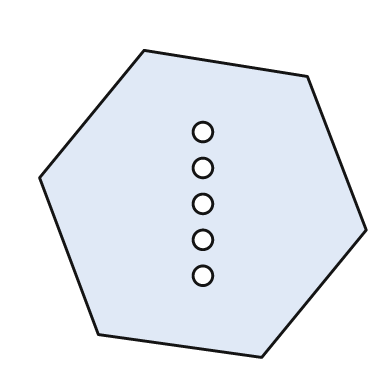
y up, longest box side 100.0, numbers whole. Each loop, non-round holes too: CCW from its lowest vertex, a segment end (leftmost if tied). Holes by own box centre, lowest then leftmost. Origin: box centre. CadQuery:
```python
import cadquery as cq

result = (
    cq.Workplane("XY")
    .moveTo(18.0, -47.0)
    .lineTo(50.0, -8.0)
    .lineTo(32.0, 39.0)
    .lineTo(-18.0, 47.0)
    .lineTo(-50.0, 8.0)
    .lineTo(-32.0, -40.0)
    .close()
    .moveTo(0.0, -22.0)
    .circle(3.0)
    .moveTo(0.0, -11.0)
    .circle(3.0)
    .moveTo(0.0, 0.0)
    .circle(3.0)
    .moveTo(0.0, 11.0)
    .circle(3.0)
    .moveTo(0.0, 22.0)
    .circle(3.0)
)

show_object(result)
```